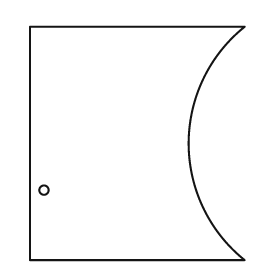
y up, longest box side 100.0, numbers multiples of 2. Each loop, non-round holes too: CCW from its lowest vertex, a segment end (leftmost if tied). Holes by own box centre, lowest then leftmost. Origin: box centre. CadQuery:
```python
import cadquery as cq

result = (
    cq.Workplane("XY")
    .moveTo(-46.0, -50.0)
    .lineTo(46.0, -50.0)
    .threePointArc((22.0, 0.0), (46.0, 50.0))
    .lineTo(-46.0, 50.0)
    .close()
    .moveTo(-40.0, -20.0)
    .circle(2.0)
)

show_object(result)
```